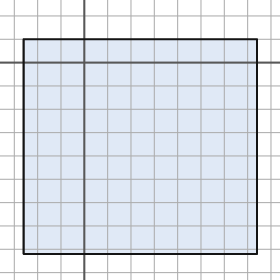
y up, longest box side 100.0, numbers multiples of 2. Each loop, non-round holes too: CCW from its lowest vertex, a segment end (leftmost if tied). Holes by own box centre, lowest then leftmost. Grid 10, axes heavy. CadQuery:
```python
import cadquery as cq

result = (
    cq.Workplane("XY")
    .moveTo(-26.0, -82.0)
    .lineTo(74.0, -82.0)
    .lineTo(74.0, 10.0)
    .lineTo(-26.0, 10.0)
    .close()
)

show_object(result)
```